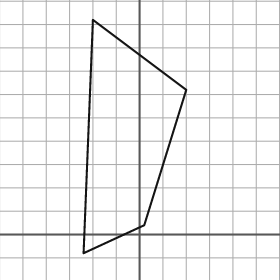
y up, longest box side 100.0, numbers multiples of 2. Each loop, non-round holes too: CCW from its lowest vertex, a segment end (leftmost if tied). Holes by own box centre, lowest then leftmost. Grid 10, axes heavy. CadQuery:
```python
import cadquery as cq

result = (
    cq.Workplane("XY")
    .moveTo(-24.0, -8.0)
    .lineTo(2.0, 4.0)
    .lineTo(20.0, 62.0)
    .lineTo(-20.0, 92.0)
    .close()
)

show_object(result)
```